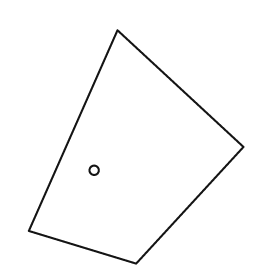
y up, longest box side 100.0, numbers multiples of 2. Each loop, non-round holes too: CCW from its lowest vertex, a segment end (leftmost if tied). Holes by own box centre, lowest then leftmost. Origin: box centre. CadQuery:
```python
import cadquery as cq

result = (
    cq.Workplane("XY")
    .moveTo(0.0, -50.0)
    .lineTo(46.0, 0.0)
    .lineTo(-8.0, 50.0)
    .lineTo(-46.0, -36.0)
    .close()
    .moveTo(-18.0, -10.0)
    .circle(2.0)
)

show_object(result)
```